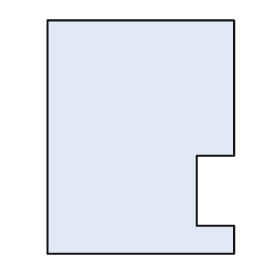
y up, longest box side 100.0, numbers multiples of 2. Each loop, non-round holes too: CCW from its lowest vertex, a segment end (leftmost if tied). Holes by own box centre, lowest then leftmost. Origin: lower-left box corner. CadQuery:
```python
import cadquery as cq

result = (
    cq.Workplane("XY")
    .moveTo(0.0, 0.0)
    .lineTo(80.0, 0.0)
    .lineTo(80.0, 12.0)
    .lineTo(64.0, 12.0)
    .lineTo(64.0, 42.0)
    .lineTo(80.0, 42.0)
    .lineTo(80.0, 100.0)
    .lineTo(0.0, 100.0)
    .close()
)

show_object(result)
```